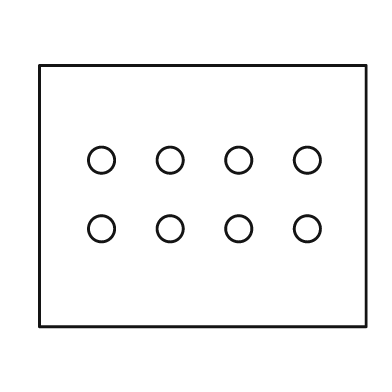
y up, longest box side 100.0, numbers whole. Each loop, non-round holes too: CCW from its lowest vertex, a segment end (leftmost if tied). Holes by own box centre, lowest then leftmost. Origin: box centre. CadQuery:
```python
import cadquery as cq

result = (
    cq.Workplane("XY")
    .moveTo(-50.0, -40.0)
    .lineTo(50.0, -40.0)
    .lineTo(50.0, 40.0)
    .lineTo(-50.0, 40.0)
    .close()
    .moveTo(-31.0, -10.0)
    .circle(4.0)
    .moveTo(-10.0, -10.0)
    .circle(4.0)
    .moveTo(11.0, -10.0)
    .circle(4.0)
    .moveTo(32.0, -10.0)
    .circle(4.0)
    .moveTo(-31.0, 11.0)
    .circle(4.0)
    .moveTo(-10.0, 11.0)
    .circle(4.0)
    .moveTo(11.0, 11.0)
    .circle(4.0)
    .moveTo(32.0, 11.0)
    .circle(4.0)
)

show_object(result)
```